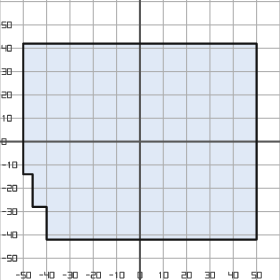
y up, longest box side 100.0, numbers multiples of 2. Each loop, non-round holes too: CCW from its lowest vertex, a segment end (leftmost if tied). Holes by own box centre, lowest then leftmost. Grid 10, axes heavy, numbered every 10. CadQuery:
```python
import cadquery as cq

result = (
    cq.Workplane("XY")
    .moveTo(-40.0, -42.0)
    .lineTo(50.0, -42.0)
    .lineTo(50.0, 42.0)
    .lineTo(-50.0, 42.0)
    .lineTo(-50.0, -14.0)
    .lineTo(-46.0, -14.0)
    .lineTo(-46.0, -28.0)
    .lineTo(-40.0, -28.0)
    .close()
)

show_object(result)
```